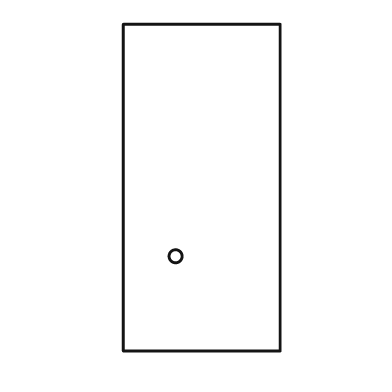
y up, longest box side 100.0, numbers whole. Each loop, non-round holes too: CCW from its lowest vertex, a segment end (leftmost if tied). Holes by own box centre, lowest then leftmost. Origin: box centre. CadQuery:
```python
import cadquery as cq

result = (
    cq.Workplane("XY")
    .moveTo(-24.0, -50.0)
    .lineTo(24.0, -50.0)
    .lineTo(24.0, 50.0)
    .lineTo(-24.0, 50.0)
    .close()
    .moveTo(-8.0, -21.0)
    .circle(2.0)
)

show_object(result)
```